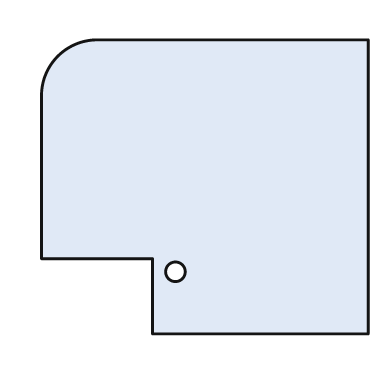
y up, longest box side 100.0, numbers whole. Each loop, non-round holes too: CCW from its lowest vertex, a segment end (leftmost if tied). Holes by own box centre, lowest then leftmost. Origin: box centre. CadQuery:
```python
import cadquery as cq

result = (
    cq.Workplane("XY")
    .moveTo(-16.0, -45.0)
    .lineTo(50.0, -45.0)
    .lineTo(50.0, 45.0)
    .lineTo(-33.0, 45.0)
    .threePointArc((-45.0, 40.0), (-50.0, 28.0))
    .lineTo(-50.0, -22.0)
    .lineTo(-16.0, -22.0)
    .close()
    .moveTo(-9.0, -26.0)
    .circle(3.0)
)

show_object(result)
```